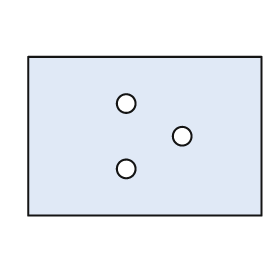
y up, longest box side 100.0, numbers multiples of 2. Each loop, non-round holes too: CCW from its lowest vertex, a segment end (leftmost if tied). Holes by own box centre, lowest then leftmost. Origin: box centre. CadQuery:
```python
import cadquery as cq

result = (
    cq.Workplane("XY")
    .moveTo(-50.0, -34.0)
    .lineTo(50.0, -34.0)
    .lineTo(50.0, 34.0)
    .lineTo(-50.0, 34.0)
    .close()
    .moveTo(-8.0, -14.0)
    .circle(4.0)
    .moveTo(16.0, 0.0)
    .circle(4.0)
    .moveTo(-8.0, 14.0)
    .circle(4.0)
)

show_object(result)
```